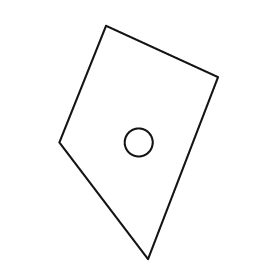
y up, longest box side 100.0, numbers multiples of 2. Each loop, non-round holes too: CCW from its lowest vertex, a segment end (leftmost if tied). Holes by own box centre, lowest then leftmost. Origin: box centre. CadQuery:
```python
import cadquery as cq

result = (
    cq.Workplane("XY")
    .moveTo(4.0, -50.0)
    .lineTo(34.0, 28.0)
    .lineTo(-14.0, 50.0)
    .lineTo(-34.0, 0.0)
    .close()
    .moveTo(0.0, 0.0)
    .circle(6.0)
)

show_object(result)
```